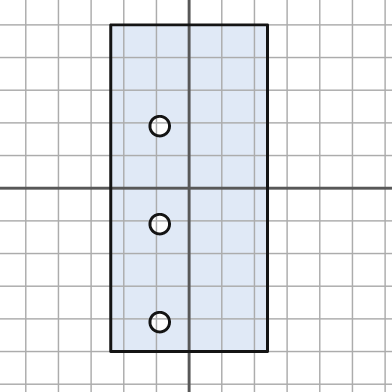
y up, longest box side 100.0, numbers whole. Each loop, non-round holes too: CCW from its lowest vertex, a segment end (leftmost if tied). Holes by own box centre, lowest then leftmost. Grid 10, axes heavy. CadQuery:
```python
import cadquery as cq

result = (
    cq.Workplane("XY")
    .moveTo(-24.0, -50.0)
    .lineTo(24.0, -50.0)
    .lineTo(24.0, 50.0)
    .lineTo(-24.0, 50.0)
    .close()
    .moveTo(-9.0, -41.0)
    .circle(3.0)
    .moveTo(-9.0, -11.0)
    .circle(3.0)
    .moveTo(-9.0, 19.0)
    .circle(3.0)
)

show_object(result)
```